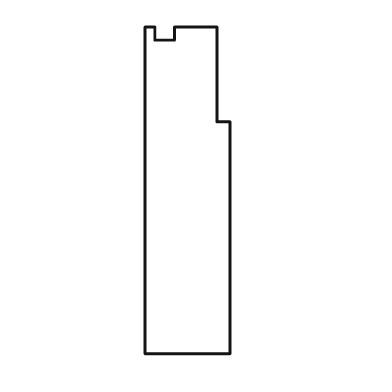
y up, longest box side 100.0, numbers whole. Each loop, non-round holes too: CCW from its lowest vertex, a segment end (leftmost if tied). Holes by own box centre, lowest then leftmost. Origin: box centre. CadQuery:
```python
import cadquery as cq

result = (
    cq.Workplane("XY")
    .moveTo(-13.0, -50.0)
    .lineTo(13.0, -50.0)
    .lineTo(13.0, 21.0)
    .lineTo(9.0, 21.0)
    .lineTo(9.0, 50.0)
    .lineTo(-4.0, 50.0)
    .lineTo(-4.0, 46.0)
    .lineTo(-10.0, 46.0)
    .lineTo(-10.0, 50.0)
    .lineTo(-13.0, 50.0)
    .close()
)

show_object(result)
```